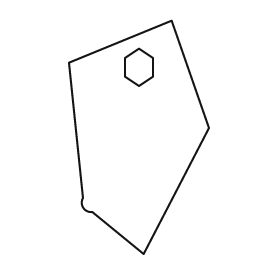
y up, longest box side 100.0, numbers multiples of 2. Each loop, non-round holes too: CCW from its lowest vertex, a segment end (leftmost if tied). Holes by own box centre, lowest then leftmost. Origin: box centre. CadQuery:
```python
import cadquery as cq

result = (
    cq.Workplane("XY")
    .moveTo(2.0, -50.0)
    .lineTo(30.0, 4.0)
    .lineTo(14.0, 50.0)
    .lineTo(-30.0, 32.0)
    .lineTo(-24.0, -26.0)
    .threePointArc((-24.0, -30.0), (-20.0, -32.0))
    .close()
    .moveTo(0.0, 22.0)
    .lineTo(6.0, 26.0)
    .lineTo(6.0, 34.0)
    .lineTo(0.0, 38.0)
    .lineTo(-6.0, 34.0)
    .lineTo(-6.0, 26.0)
    .close()
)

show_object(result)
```